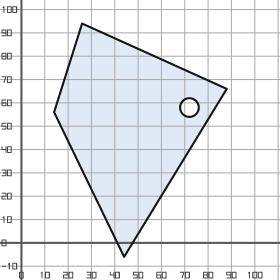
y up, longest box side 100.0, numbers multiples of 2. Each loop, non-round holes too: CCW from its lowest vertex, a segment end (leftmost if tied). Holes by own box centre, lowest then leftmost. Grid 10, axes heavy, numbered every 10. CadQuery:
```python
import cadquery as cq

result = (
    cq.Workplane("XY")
    .moveTo(44.0, -6.0)
    .lineTo(88.0, 66.0)
    .lineTo(26.0, 94.0)
    .lineTo(14.0, 56.0)
    .close()
    .moveTo(72.0, 58.0)
    .circle(4.0)
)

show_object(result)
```